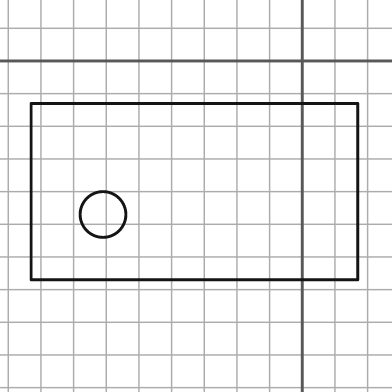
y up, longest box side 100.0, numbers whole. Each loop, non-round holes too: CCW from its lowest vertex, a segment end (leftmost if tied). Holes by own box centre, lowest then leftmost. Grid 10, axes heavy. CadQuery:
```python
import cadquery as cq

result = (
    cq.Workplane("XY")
    .moveTo(-83.0, -67.0)
    .lineTo(17.0, -67.0)
    .lineTo(17.0, -13.0)
    .lineTo(-83.0, -13.0)
    .close()
    .moveTo(-61.0, -47.0)
    .circle(7.0)
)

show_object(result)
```